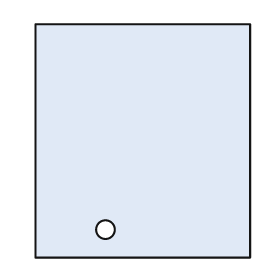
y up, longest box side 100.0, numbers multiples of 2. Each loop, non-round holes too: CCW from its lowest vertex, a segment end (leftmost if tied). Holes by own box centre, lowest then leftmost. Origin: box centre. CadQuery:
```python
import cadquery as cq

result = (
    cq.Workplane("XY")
    .moveTo(-46.0, -50.0)
    .lineTo(46.0, -50.0)
    .lineTo(46.0, 50.0)
    .lineTo(-46.0, 50.0)
    .close()
    .moveTo(-16.0, -38.0)
    .circle(4.0)
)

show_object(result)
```